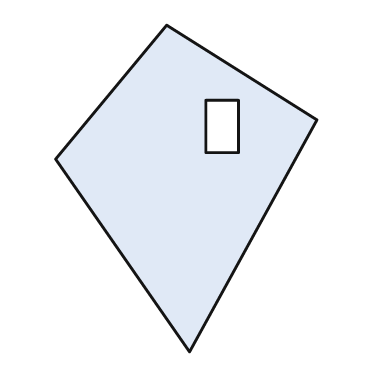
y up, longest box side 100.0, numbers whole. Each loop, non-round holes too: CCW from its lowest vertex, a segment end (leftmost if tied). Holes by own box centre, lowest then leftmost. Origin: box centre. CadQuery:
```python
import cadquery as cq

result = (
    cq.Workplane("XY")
    .moveTo(1.0, -50.0)
    .lineTo(40.0, 21.0)
    .lineTo(-6.0, 50.0)
    .lineTo(-40.0, 9.0)
    .close()
    .moveTo(6.0, 11.0)
    .lineTo(16.0, 11.0)
    .lineTo(16.0, 27.0)
    .lineTo(6.0, 27.0)
    .close()
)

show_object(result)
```